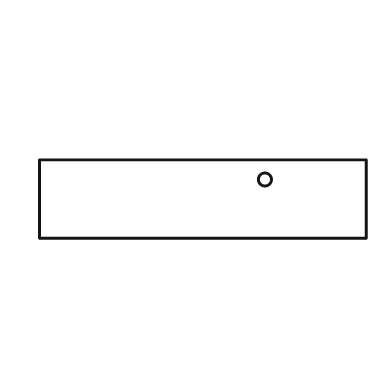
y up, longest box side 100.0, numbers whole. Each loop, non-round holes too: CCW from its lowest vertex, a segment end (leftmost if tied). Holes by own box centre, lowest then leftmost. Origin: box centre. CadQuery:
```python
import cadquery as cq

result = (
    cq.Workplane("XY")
    .moveTo(-50.0, -12.0)
    .lineTo(50.0, -12.0)
    .lineTo(50.0, 12.0)
    .lineTo(-50.0, 12.0)
    .close()
    .moveTo(19.0, 6.0)
    .circle(2.0)
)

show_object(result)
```